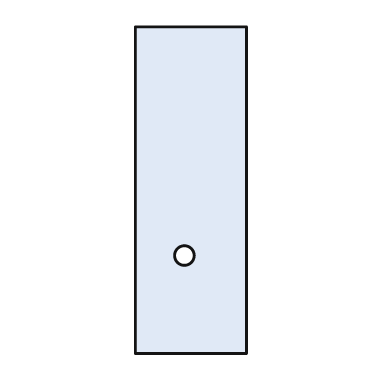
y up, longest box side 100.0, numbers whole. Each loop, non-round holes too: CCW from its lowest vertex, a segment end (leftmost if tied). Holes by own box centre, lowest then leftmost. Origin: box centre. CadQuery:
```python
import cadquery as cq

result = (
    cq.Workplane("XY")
    .moveTo(-17.0, -50.0)
    .lineTo(17.0, -50.0)
    .lineTo(17.0, 50.0)
    .lineTo(-17.0, 50.0)
    .close()
    .moveTo(-2.0, -20.0)
    .circle(3.0)
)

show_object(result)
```